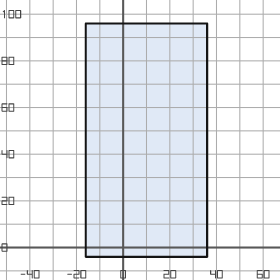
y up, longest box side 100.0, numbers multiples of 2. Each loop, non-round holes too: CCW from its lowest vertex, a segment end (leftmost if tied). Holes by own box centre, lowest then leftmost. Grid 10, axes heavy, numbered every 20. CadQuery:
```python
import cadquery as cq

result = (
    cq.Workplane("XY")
    .moveTo(-16.0, -4.0)
    .lineTo(36.0, -4.0)
    .lineTo(36.0, 96.0)
    .lineTo(-16.0, 96.0)
    .close()
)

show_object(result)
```